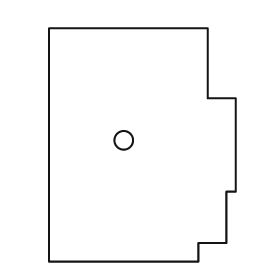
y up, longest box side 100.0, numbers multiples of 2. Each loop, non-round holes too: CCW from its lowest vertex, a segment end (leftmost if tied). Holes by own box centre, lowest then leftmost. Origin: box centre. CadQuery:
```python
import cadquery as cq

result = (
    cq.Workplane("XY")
    .moveTo(-40.0, -50.0)
    .lineTo(24.0, -50.0)
    .lineTo(24.0, -42.0)
    .lineTo(36.0, -42.0)
    .lineTo(36.0, -20.0)
    .lineTo(40.0, -20.0)
    .lineTo(40.0, 20.0)
    .lineTo(28.0, 20.0)
    .lineTo(28.0, 50.0)
    .lineTo(-40.0, 50.0)
    .close()
    .moveTo(-8.0, 2.0)
    .circle(4.0)
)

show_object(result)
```